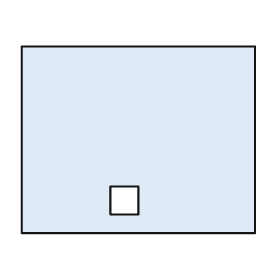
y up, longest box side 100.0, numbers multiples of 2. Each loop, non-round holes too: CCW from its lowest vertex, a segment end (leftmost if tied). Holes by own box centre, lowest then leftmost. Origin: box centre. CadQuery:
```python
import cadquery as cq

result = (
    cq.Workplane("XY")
    .moveTo(-50.0, -40.0)
    .lineTo(50.0, -40.0)
    .lineTo(50.0, 40.0)
    .lineTo(-50.0, 40.0)
    .close()
    .moveTo(-12.0, -32.0)
    .lineTo(0.0, -32.0)
    .lineTo(0.0, -20.0)
    .lineTo(-12.0, -20.0)
    .close()
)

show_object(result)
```